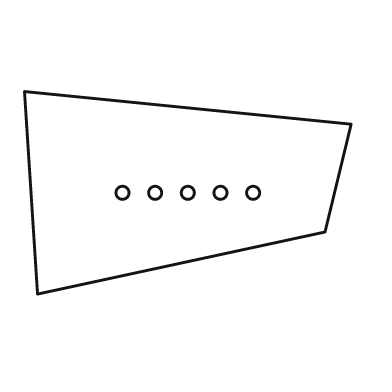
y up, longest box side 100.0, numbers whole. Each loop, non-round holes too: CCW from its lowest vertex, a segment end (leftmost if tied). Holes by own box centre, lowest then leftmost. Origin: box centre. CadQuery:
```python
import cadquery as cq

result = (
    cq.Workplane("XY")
    .moveTo(-46.0, -31.0)
    .lineTo(42.0, -12.0)
    .lineTo(50.0, 21.0)
    .lineTo(-50.0, 31.0)
    .close()
    .moveTo(-20.0, 0.0)
    .circle(2.0)
    .moveTo(-10.0, 0.0)
    .circle(2.0)
    .moveTo(0.0, 0.0)
    .circle(2.0)
    .moveTo(10.0, 0.0)
    .circle(2.0)
    .moveTo(20.0, 0.0)
    .circle(2.0)
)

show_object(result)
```